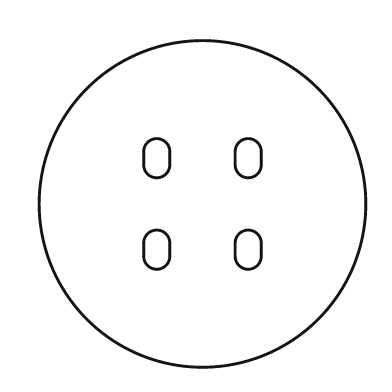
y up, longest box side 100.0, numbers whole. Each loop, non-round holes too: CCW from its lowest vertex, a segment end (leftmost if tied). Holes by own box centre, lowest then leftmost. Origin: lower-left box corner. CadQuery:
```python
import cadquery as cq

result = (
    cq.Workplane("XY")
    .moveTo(50.0, 50.0)
    .circle(50.0)
    .moveTo(32.0, 34.0)
    .threePointArc((36.0, 30.0), (40.0, 34.0))
    .lineTo(40.0, 38.0)
    .threePointArc((36.0, 42.0), (32.0, 38.0))
    .close()
    .moveTo(60.0, 34.0)
    .threePointArc((64.0, 30.0), (68.0, 34.0))
    .lineTo(68.0, 38.0)
    .threePointArc((64.0, 42.0), (60.0, 38.0))
    .close()
    .moveTo(32.0, 62.0)
    .threePointArc((36.0, 58.0), (40.0, 62.0))
    .lineTo(40.0, 66.0)
    .threePointArc((36.0, 70.0), (32.0, 66.0))
    .close()
    .moveTo(60.0, 62.0)
    .threePointArc((64.0, 58.0), (68.0, 62.0))
    .lineTo(68.0, 66.0)
    .threePointArc((64.0, 70.0), (60.0, 66.0))
    .close()
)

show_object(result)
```